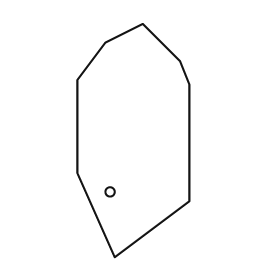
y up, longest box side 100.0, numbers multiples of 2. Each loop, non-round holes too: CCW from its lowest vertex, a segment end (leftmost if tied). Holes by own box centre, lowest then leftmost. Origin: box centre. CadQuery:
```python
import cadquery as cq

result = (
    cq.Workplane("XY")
    .moveTo(-8.0, -50.0)
    .lineTo(24.0, -26.0)
    .lineTo(24.0, 24.0)
    .lineTo(20.0, 34.0)
    .lineTo(4.0, 50.0)
    .lineTo(-12.0, 42.0)
    .lineTo(-24.0, 26.0)
    .lineTo(-24.0, -14.0)
    .close()
    .moveTo(-10.0, -22.0)
    .circle(2.0)
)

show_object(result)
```